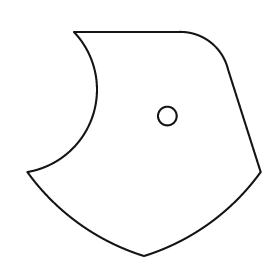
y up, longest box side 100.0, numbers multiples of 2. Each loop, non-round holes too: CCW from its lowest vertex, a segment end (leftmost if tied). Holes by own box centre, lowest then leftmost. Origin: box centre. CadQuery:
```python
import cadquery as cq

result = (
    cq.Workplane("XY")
    .moveTo(0.0, -48.0)
    .threePointArc((28.0, -34.0), (50.0, -12.0))
    .lineTo(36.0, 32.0)
    .threePointArc((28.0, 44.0), (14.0, 48.0))
    .lineTo(-30.0, 48.0)
    .threePointArc((-22.0, 12.0), (-50.0, -12.0))
    .threePointArc((-28.0, -34.0), (0.0, -48.0))
    .close()
    .moveTo(10.0, 12.0)
    .circle(4.0)
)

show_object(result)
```